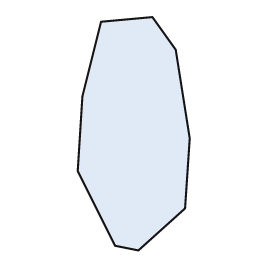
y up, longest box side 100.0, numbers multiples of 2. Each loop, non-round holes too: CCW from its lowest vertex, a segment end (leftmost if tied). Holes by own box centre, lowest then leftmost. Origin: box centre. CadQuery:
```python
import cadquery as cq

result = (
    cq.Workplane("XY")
    .moveTo(2.0, -50.0)
    .lineTo(22.0, -32.0)
    .lineTo(24.0, -2.0)
    .lineTo(18.0, 36.0)
    .lineTo(8.0, 50.0)
    .lineTo(-14.0, 48.0)
    .lineTo(-22.0, 16.0)
    .lineTo(-24.0, -16.0)
    .lineTo(-8.0, -48.0)
    .close()
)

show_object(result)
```